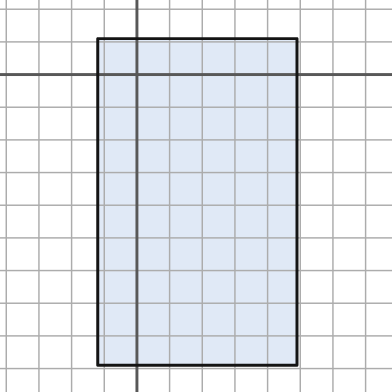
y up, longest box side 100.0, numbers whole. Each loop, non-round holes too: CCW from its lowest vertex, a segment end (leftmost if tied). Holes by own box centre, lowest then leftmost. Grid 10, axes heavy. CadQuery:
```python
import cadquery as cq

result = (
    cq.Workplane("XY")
    .moveTo(-12.0, -89.0)
    .lineTo(49.0, -89.0)
    .lineTo(49.0, 11.0)
    .lineTo(-12.0, 11.0)
    .close()
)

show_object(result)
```